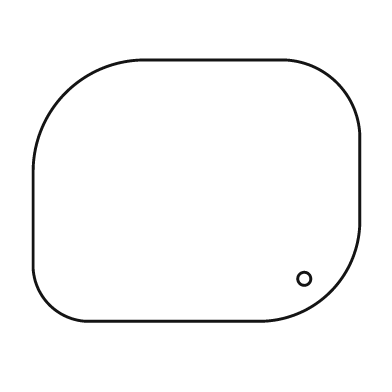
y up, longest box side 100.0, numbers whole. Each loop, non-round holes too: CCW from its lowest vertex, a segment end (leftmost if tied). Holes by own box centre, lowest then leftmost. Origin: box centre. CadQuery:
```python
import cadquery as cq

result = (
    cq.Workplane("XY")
    .moveTo(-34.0, -40.0)
    .lineTo(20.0, -40.0)
    .threePointArc((41.0, -31.0), (50.0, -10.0))
    .lineTo(50.0, 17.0)
    .threePointArc((43.0, 33.0), (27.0, 40.0))
    .lineTo(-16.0, 40.0)
    .threePointArc((-40.0, 30.0), (-50.0, 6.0))
    .lineTo(-50.0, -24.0)
    .threePointArc((-45.0, -35.0), (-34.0, -40.0))
    .close()
    .moveTo(33.0, -27.0)
    .circle(2.0)
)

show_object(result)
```